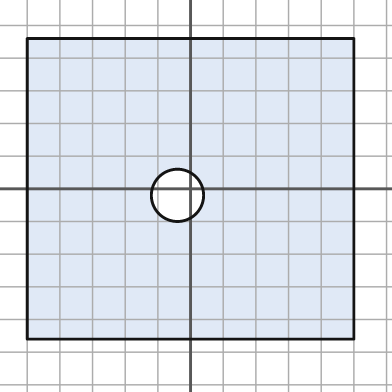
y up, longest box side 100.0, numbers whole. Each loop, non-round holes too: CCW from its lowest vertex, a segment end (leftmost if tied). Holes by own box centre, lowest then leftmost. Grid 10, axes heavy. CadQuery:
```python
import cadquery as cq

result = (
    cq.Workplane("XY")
    .moveTo(-50.0, -46.0)
    .lineTo(50.0, -46.0)
    .lineTo(50.0, 46.0)
    .lineTo(-50.0, 46.0)
    .close()
    .moveTo(-4.0, -2.0)
    .circle(8.0)
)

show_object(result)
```